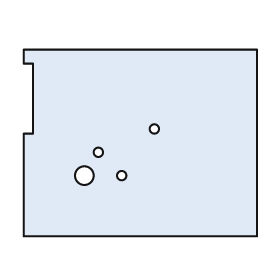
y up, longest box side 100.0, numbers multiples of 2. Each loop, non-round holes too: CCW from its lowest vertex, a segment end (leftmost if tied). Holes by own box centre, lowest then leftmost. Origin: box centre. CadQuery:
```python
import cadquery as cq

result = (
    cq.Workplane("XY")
    .moveTo(-50.0, -40.0)
    .lineTo(50.0, -40.0)
    .lineTo(50.0, 40.0)
    .lineTo(-50.0, 40.0)
    .lineTo(-50.0, 34.0)
    .lineTo(-46.0, 34.0)
    .lineTo(-46.0, 4.0)
    .lineTo(-50.0, 4.0)
    .close()
    .moveTo(-24.0, -14.0)
    .circle(4.0)
    .moveTo(-8.0, -14.0)
    .circle(2.0)
    .moveTo(-18.0, -4.0)
    .circle(2.0)
    .moveTo(6.0, 6.0)
    .circle(2.0)
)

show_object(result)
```